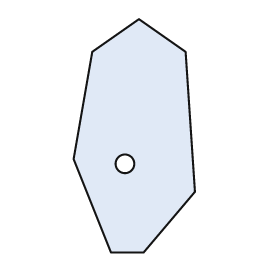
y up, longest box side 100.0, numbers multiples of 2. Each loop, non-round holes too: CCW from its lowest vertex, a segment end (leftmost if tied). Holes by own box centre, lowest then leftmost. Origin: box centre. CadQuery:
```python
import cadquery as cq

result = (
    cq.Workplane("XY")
    .moveTo(-10.0, -50.0)
    .lineTo(4.0, -50.0)
    .lineTo(26.0, -24.0)
    .lineTo(22.0, 36.0)
    .lineTo(2.0, 50.0)
    .lineTo(-18.0, 36.0)
    .lineTo(-26.0, -10.0)
    .close()
    .moveTo(-4.0, -12.0)
    .circle(4.0)
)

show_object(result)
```